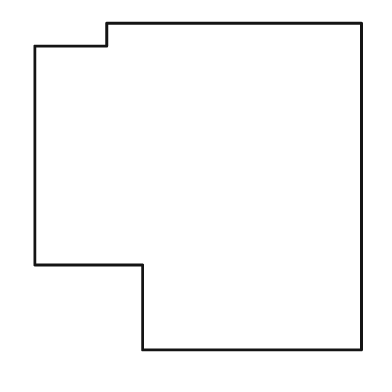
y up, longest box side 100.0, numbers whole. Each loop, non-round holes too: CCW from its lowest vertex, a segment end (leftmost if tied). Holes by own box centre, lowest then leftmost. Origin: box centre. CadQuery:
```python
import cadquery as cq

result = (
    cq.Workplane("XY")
    .moveTo(-17.0, -50.0)
    .lineTo(50.0, -50.0)
    .lineTo(50.0, 50.0)
    .lineTo(-28.0, 50.0)
    .lineTo(-28.0, 43.0)
    .lineTo(-50.0, 43.0)
    .lineTo(-50.0, -24.0)
    .lineTo(-17.0, -24.0)
    .close()
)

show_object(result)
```